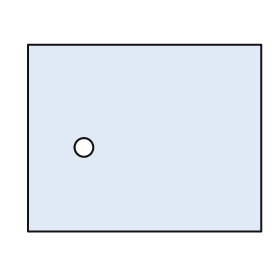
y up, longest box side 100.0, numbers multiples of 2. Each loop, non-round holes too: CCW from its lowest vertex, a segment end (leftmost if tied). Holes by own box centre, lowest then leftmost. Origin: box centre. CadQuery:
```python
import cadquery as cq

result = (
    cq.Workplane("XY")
    .moveTo(-50.0, -40.0)
    .lineTo(50.0, -40.0)
    .lineTo(50.0, 40.0)
    .lineTo(-50.0, 40.0)
    .close()
    .moveTo(-26.0, -4.0)
    .circle(4.0)
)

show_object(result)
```